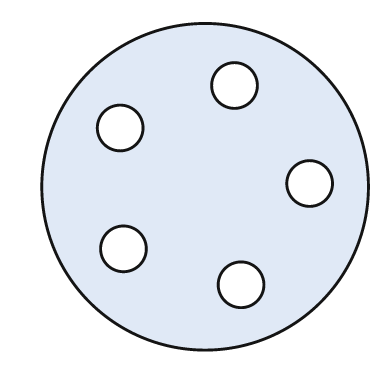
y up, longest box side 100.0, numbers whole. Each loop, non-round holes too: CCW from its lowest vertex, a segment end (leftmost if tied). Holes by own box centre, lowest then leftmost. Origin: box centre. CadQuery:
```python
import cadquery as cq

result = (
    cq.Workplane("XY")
    .moveTo(0.0, 0.0)
    .circle(50.0)
    .moveTo(11.0, -30.0)
    .circle(7.0)
    .moveTo(-25.0, -19.0)
    .circle(7.0)
    .moveTo(32.0, 1.0)
    .circle(7.0)
    .moveTo(-26.0, 18.0)
    .circle(7.0)
    .moveTo(9.0, 31.0)
    .circle(7.0)
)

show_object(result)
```